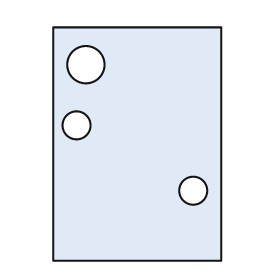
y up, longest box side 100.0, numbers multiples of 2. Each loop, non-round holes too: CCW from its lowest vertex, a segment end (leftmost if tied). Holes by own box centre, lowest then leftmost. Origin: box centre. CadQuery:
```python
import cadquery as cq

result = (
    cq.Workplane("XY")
    .moveTo(-36.0, -50.0)
    .lineTo(36.0, -50.0)
    .lineTo(36.0, 50.0)
    .lineTo(-36.0, 50.0)
    .close()
    .moveTo(24.0, -20.0)
    .circle(6.0)
    .moveTo(-26.0, 8.0)
    .circle(6.0)
    .moveTo(-22.0, 34.0)
    .circle(8.0)
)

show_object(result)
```